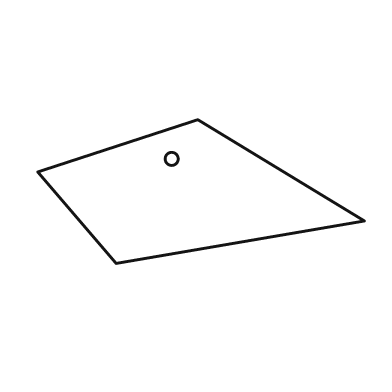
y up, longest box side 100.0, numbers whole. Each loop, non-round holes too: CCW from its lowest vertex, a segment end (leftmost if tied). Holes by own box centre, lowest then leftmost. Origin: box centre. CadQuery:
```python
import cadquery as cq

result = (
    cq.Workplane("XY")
    .moveTo(-26.0, -22.0)
    .lineTo(50.0, -9.0)
    .lineTo(-1.0, 22.0)
    .lineTo(-50.0, 6.0)
    .close()
    .moveTo(-9.0, 10.0)
    .circle(2.0)
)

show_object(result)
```